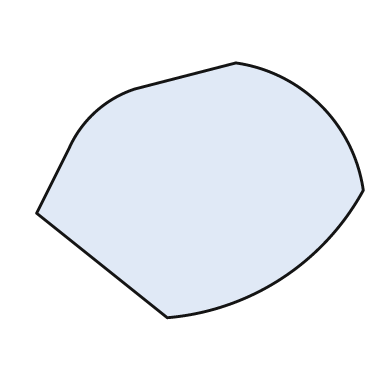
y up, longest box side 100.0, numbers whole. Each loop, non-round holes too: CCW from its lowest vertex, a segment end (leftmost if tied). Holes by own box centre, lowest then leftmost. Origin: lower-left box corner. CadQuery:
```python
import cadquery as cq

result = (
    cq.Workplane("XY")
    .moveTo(40.0, 0.0)
    .threePointArc((75.0, 12.0), (100.0, 39.0))
    .threePointArc((87.0, 65.0), (61.0, 78.0))
    .lineTo(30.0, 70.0)
    .threePointArc((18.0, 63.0), (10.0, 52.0))
    .lineTo(0.0, 32.0)
    .close()
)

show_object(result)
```